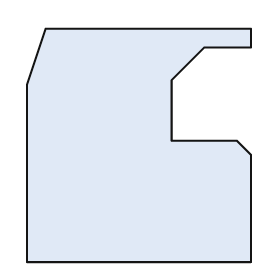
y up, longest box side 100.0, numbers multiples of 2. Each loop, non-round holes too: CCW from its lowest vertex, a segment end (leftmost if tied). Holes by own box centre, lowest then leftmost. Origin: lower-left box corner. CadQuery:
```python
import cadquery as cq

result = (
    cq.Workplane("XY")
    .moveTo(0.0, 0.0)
    .lineTo(96.0, 0.0)
    .lineTo(96.0, 46.0)
    .lineTo(90.0, 52.0)
    .lineTo(62.0, 52.0)
    .lineTo(62.0, 78.0)
    .lineTo(76.0, 92.0)
    .lineTo(96.0, 92.0)
    .lineTo(96.0, 100.0)
    .lineTo(8.0, 100.0)
    .lineTo(0.0, 76.0)
    .close()
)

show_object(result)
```